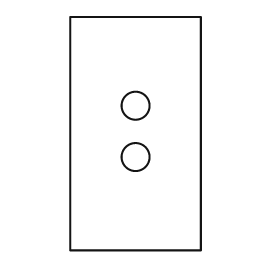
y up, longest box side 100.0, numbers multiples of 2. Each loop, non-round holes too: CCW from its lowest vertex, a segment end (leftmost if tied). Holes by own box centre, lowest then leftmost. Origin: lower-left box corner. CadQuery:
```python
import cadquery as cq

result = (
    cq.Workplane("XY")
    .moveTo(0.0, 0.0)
    .lineTo(56.0, 0.0)
    .lineTo(56.0, 100.0)
    .lineTo(0.0, 100.0)
    .close()
    .moveTo(28.0, 40.0)
    .circle(6.0)
    .moveTo(28.0, 62.0)
    .circle(6.0)
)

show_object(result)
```